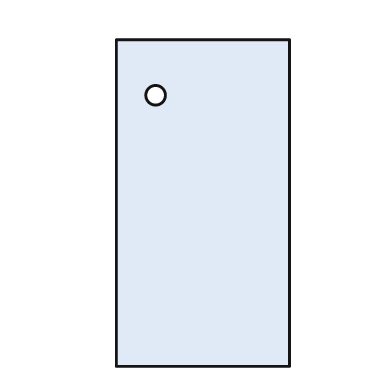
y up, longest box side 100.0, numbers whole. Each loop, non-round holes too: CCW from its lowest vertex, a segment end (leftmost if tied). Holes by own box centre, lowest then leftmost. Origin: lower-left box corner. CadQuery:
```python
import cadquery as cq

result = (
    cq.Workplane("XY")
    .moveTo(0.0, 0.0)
    .lineTo(53.0, 0.0)
    .lineTo(53.0, 100.0)
    .lineTo(0.0, 100.0)
    .close()
    .moveTo(12.0, 83.0)
    .circle(3.0)
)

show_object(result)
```